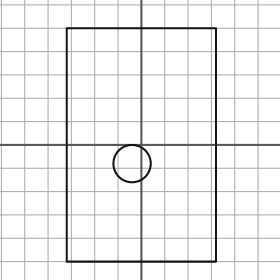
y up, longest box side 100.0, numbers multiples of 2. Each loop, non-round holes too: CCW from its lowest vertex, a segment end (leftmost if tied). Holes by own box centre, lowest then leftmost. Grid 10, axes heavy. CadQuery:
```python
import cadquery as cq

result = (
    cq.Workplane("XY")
    .moveTo(-32.0, -50.0)
    .lineTo(32.0, -50.0)
    .lineTo(32.0, 50.0)
    .lineTo(-32.0, 50.0)
    .close()
    .moveTo(-4.0, -8.0)
    .circle(8.0)
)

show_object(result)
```